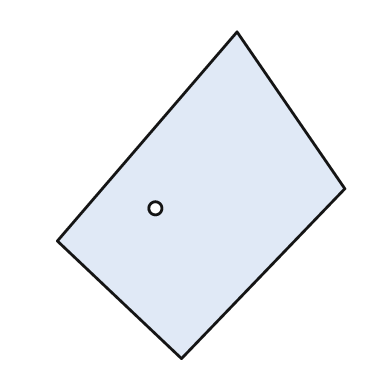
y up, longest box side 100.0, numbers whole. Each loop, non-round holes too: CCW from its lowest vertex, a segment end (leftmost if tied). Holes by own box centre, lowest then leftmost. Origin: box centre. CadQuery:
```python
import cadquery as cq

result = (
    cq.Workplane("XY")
    .moveTo(-6.0, -50.0)
    .lineTo(44.0, 2.0)
    .lineTo(11.0, 50.0)
    .lineTo(-44.0, -14.0)
    .close()
    .moveTo(-14.0, -4.0)
    .circle(2.0)
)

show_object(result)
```